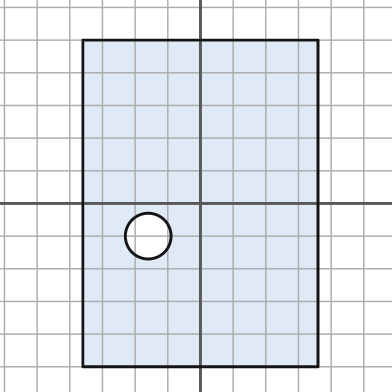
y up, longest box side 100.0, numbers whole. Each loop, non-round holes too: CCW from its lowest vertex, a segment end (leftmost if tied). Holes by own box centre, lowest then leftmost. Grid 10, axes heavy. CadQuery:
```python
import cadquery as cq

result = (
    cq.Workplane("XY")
    .moveTo(-36.0, -50.0)
    .lineTo(36.0, -50.0)
    .lineTo(36.0, 50.0)
    .lineTo(-36.0, 50.0)
    .close()
    .moveTo(-16.0, -10.0)
    .circle(7.0)
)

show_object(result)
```